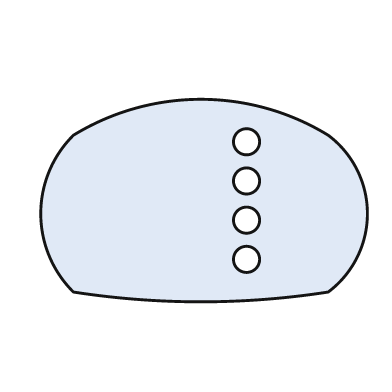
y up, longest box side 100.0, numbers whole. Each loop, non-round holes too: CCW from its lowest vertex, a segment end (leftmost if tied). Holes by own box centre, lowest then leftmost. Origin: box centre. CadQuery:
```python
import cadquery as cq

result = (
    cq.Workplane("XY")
    .moveTo(-40.0, -28.0)
    .threePointArc((-1.0, -31.0), (38.0, -28.0))
    .threePointArc((50.0, -4.0), (38.0, 20.0))
    .threePointArc((-1.0, 31.0), (-40.0, 20.0))
    .threePointArc((-50.0, -4.0), (-40.0, -28.0))
    .close()
    .moveTo(13.0, -18.0)
    .circle(4.0)
    .moveTo(13.0, -6.0)
    .circle(4.0)
    .moveTo(13.0, 6.0)
    .circle(4.0)
    .moveTo(13.0, 18.0)
    .circle(4.0)
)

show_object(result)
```